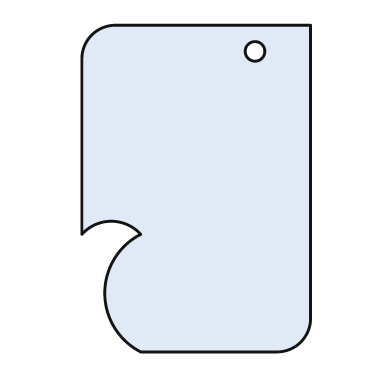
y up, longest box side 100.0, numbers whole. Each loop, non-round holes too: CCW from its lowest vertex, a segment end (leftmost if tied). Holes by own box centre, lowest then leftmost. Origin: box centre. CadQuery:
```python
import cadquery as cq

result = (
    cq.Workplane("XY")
    .moveTo(-17.0, -50.0)
    .lineTo(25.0, -50.0)
    .threePointArc((32.0, -47.0), (35.0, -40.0))
    .lineTo(35.0, 50.0)
    .lineTo(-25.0, 50.0)
    .threePointArc((-32.0, 47.0), (-35.0, 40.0))
    .lineTo(-35.0, -14.0)
    .threePointArc((-26.0, -10.0), (-17.0, -14.0))
    .threePointArc((-28.0, -32.0), (-17.0, -50.0))
    .close()
    .moveTo(18.0, 42.0)
    .circle(3.0)
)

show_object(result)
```